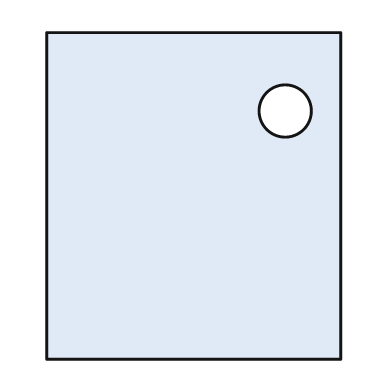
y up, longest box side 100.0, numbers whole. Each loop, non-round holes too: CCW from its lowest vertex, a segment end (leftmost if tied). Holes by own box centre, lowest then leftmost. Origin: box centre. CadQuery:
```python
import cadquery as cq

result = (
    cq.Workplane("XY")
    .moveTo(-45.0, -50.0)
    .lineTo(45.0, -50.0)
    .lineTo(45.0, 50.0)
    .lineTo(-45.0, 50.0)
    .close()
    .moveTo(28.0, 26.0)
    .circle(8.0)
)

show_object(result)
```